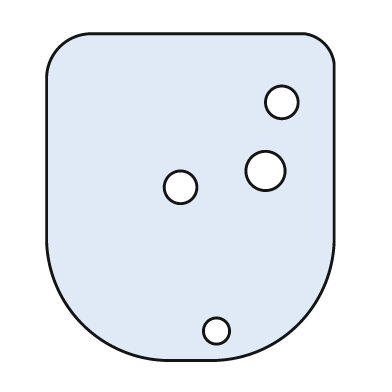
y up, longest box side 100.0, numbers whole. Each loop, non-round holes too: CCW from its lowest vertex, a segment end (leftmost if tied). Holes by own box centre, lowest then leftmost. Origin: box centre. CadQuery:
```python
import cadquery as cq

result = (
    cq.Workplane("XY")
    .moveTo(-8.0, -50.0)
    .lineTo(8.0, -50.0)
    .threePointArc((33.0, -39.0), (44.0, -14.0))
    .lineTo(44.0, 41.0)
    .threePointArc((41.0, 47.0), (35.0, 50.0))
    .lineTo(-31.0, 50.0)
    .threePointArc((-40.0, 46.0), (-44.0, 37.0))
    .lineTo(-44.0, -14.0)
    .threePointArc((-33.0, -39.0), (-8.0, -50.0))
    .close()
    .moveTo(8.0, -41.0)
    .circle(4.0)
    .moveTo(-3.0, 3.0)
    .circle(5.0)
    .moveTo(23.0, 8.0)
    .circle(6.0)
    .moveTo(28.0, 29.0)
    .circle(5.0)
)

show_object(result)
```